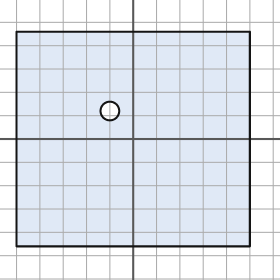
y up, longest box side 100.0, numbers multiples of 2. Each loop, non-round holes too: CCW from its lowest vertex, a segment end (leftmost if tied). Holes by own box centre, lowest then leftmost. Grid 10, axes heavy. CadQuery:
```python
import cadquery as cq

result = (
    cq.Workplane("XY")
    .moveTo(-50.0, -46.0)
    .lineTo(50.0, -46.0)
    .lineTo(50.0, 46.0)
    .lineTo(-50.0, 46.0)
    .close()
    .moveTo(-10.0, 12.0)
    .circle(4.0)
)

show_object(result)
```